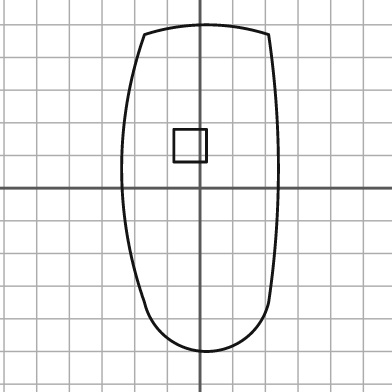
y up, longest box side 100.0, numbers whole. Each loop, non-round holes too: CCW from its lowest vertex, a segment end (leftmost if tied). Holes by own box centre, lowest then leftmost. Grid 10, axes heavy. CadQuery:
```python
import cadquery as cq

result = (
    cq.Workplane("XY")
    .moveTo(-17.0, -35.0)
    .threePointArc((2.0, -50.0), (21.0, -35.0))
    .threePointArc((24.0, 6.0), (21.0, 47.0))
    .threePointArc((2.0, 50.0), (-17.0, 47.0))
    .threePointArc((-24.0, 6.0), (-17.0, -35.0))
    .close()
    .moveTo(-8.0, 8.0)
    .lineTo(2.0, 8.0)
    .lineTo(2.0, 18.0)
    .lineTo(-8.0, 18.0)
    .close()
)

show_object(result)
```